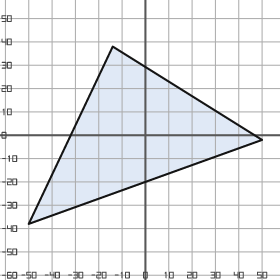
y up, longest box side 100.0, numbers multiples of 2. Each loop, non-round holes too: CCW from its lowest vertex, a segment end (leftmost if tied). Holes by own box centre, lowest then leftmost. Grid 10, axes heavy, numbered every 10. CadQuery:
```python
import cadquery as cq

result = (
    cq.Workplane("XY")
    .moveTo(-50.0, -38.0)
    .lineTo(50.0, -2.0)
    .lineTo(-14.0, 38.0)
    .close()
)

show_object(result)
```